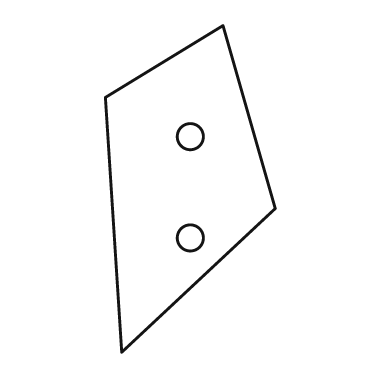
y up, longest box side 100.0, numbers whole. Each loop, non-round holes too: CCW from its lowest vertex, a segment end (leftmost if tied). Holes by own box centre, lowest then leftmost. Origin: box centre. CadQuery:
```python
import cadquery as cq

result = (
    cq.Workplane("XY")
    .moveTo(-21.0, -50.0)
    .lineTo(26.0, -6.0)
    .lineTo(10.0, 50.0)
    .lineTo(-26.0, 28.0)
    .close()
    .moveTo(0.0, -15.0)
    .circle(4.0)
    .moveTo(0.0, 16.0)
    .circle(4.0)
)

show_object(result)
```